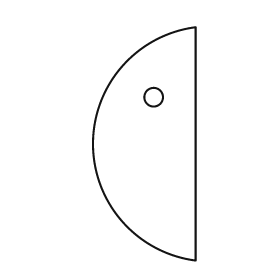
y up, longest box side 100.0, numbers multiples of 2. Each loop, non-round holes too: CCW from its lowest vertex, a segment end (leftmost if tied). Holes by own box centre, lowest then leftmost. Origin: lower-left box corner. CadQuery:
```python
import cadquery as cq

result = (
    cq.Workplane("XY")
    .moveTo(44.0, 0.0)
    .lineTo(44.0, 100.0)
    .threePointArc((0.0, 50.0), (44.0, 0.0))
    .close()
    .moveTo(26.0, 70.0)
    .circle(4.0)
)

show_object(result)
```